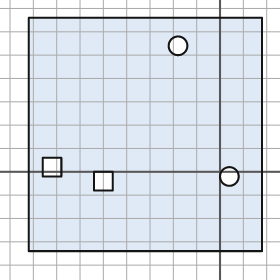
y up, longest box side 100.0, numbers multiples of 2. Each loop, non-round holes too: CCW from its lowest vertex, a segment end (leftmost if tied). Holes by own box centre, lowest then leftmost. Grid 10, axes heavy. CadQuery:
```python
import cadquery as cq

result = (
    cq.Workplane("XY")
    .moveTo(-82.0, -34.0)
    .lineTo(18.0, -34.0)
    .lineTo(18.0, 66.0)
    .lineTo(-82.0, 66.0)
    .close()
    .moveTo(-54.0, -8.0)
    .lineTo(-46.0, -8.0)
    .lineTo(-46.0, 0.0)
    .lineTo(-54.0, 0.0)
    .close()
    .moveTo(4.0, -2.0)
    .circle(4.0)
    .moveTo(-76.0, -2.0)
    .lineTo(-68.0, -2.0)
    .lineTo(-68.0, 6.0)
    .lineTo(-76.0, 6.0)
    .close()
    .moveTo(-18.0, 54.0)
    .circle(4.0)
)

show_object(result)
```